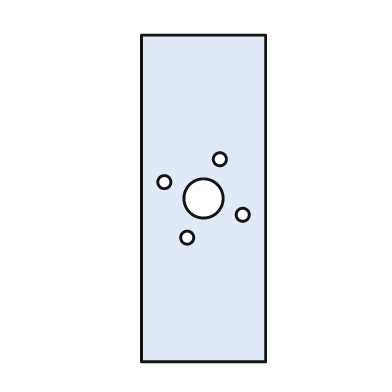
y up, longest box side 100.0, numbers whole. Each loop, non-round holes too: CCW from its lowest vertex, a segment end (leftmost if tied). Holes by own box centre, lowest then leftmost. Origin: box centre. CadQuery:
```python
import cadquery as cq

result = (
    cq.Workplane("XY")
    .moveTo(-19.0, -50.0)
    .lineTo(19.0, -50.0)
    .lineTo(19.0, 50.0)
    .lineTo(-19.0, 50.0)
    .close()
    .moveTo(-5.0, -12.0)
    .circle(2.0)
    .moveTo(12.0, -5.0)
    .circle(2.0)
    .moveTo(0.0, 0.0)
    .circle(6.0)
    .moveTo(-12.0, 5.0)
    .circle(2.0)
    .moveTo(5.0, 12.0)
    .circle(2.0)
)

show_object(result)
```